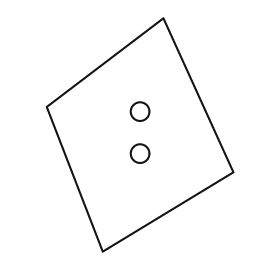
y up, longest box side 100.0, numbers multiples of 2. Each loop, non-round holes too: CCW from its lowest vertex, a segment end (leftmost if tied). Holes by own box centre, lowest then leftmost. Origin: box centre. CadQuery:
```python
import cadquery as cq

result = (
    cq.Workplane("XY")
    .moveTo(-16.0, -50.0)
    .lineTo(40.0, -16.0)
    .lineTo(10.0, 50.0)
    .lineTo(-40.0, 12.0)
    .close()
    .moveTo(0.0, -8.0)
    .circle(4.0)
    .moveTo(0.0, 10.0)
    .circle(4.0)
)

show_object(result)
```